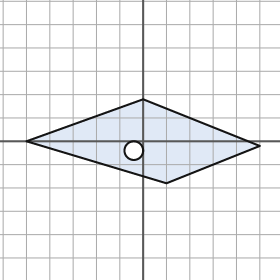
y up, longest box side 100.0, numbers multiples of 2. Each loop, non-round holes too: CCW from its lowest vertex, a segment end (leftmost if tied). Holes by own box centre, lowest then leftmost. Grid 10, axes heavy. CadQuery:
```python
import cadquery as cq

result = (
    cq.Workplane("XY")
    .moveTo(10.0, -18.0)
    .lineTo(50.0, -2.0)
    .lineTo(0.0, 18.0)
    .lineTo(-50.0, 0.0)
    .close()
    .moveTo(-4.0, -4.0)
    .circle(4.0)
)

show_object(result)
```